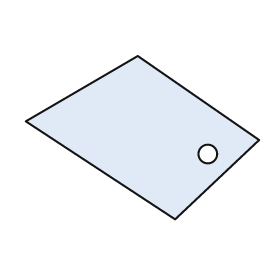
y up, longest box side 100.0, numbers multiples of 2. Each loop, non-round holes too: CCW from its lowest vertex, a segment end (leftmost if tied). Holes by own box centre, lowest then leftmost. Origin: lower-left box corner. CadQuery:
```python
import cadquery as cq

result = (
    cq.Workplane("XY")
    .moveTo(64.0, 0.0)
    .lineTo(100.0, 34.0)
    .lineTo(48.0, 70.0)
    .lineTo(0.0, 42.0)
    .close()
    .moveTo(78.0, 28.0)
    .circle(4.0)
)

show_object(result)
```